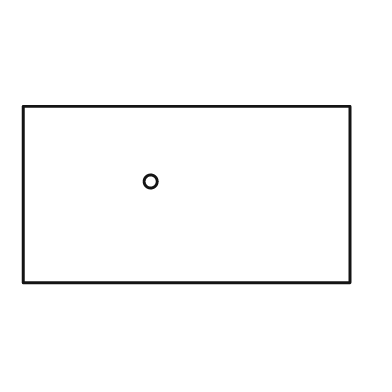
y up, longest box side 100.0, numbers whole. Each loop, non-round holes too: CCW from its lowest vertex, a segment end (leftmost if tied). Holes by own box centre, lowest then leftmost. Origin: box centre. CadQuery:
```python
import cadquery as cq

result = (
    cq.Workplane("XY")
    .moveTo(-50.0, -27.0)
    .lineTo(50.0, -27.0)
    .lineTo(50.0, 27.0)
    .lineTo(-50.0, 27.0)
    .close()
    .moveTo(-11.0, 4.0)
    .circle(2.0)
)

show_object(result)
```